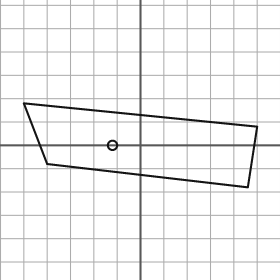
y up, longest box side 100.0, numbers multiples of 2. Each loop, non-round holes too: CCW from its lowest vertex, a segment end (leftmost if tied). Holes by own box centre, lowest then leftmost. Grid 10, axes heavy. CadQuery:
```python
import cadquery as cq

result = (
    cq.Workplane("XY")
    .moveTo(46.0, -18.0)
    .lineTo(50.0, 8.0)
    .lineTo(-50.0, 18.0)
    .lineTo(-40.0, -8.0)
    .close()
    .moveTo(-12.0, 0.0)
    .circle(2.0)
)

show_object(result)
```